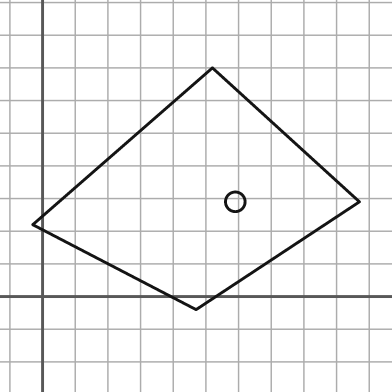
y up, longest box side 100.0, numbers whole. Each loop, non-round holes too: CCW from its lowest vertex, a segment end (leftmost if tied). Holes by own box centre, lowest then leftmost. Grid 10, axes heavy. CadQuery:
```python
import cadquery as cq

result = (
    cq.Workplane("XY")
    .moveTo(47.0, -4.0)
    .lineTo(97.0, 29.0)
    .lineTo(52.0, 70.0)
    .lineTo(-3.0, 22.0)
    .close()
    .moveTo(59.0, 29.0)
    .circle(3.0)
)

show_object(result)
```